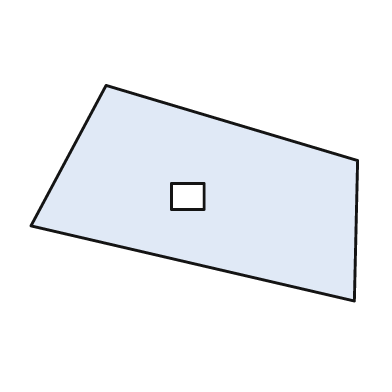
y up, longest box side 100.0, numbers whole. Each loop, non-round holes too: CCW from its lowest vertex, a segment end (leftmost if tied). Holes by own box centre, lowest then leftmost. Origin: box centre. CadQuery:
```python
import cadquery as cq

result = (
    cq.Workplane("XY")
    .moveTo(49.0, -33.0)
    .lineTo(50.0, 10.0)
    .lineTo(-27.0, 33.0)
    .lineTo(-50.0, -10.0)
    .close()
    .moveTo(-7.0, -5.0)
    .lineTo(3.0, -5.0)
    .lineTo(3.0, 3.0)
    .lineTo(-7.0, 3.0)
    .close()
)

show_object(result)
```